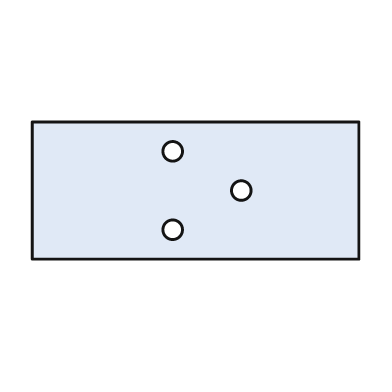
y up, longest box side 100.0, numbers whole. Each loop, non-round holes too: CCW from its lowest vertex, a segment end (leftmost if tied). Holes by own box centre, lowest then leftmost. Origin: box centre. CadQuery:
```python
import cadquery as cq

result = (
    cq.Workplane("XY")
    .moveTo(-50.0, -21.0)
    .lineTo(50.0, -21.0)
    .lineTo(50.0, 21.0)
    .lineTo(-50.0, 21.0)
    .close()
    .moveTo(-7.0, -12.0)
    .circle(3.0)
    .moveTo(14.0, 0.0)
    .circle(3.0)
    .moveTo(-7.0, 12.0)
    .circle(3.0)
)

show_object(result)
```